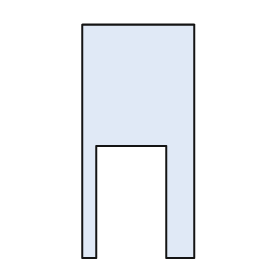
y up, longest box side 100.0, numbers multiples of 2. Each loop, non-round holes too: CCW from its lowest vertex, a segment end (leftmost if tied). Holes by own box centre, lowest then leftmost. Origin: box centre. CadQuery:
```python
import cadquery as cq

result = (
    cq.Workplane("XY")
    .moveTo(-24.0, -50.0)
    .lineTo(-18.0, -50.0)
    .lineTo(-18.0, -2.0)
    .lineTo(12.0, -2.0)
    .lineTo(12.0, -50.0)
    .lineTo(24.0, -50.0)
    .lineTo(24.0, 50.0)
    .lineTo(-24.0, 50.0)
    .close()
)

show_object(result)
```